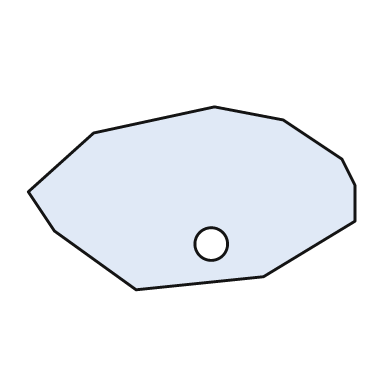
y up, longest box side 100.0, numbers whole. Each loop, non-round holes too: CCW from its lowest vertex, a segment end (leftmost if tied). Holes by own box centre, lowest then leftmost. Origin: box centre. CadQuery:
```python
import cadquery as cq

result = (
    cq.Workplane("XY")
    .moveTo(-17.0, -28.0)
    .lineTo(22.0, -24.0)
    .lineTo(50.0, -7.0)
    .lineTo(50.0, 4.0)
    .lineTo(46.0, 12.0)
    .lineTo(28.0, 24.0)
    .lineTo(7.0, 28.0)
    .lineTo(-30.0, 20.0)
    .lineTo(-50.0, 2.0)
    .lineTo(-42.0, -10.0)
    .close()
    .moveTo(6.0, -14.0)
    .circle(5.0)
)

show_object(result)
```